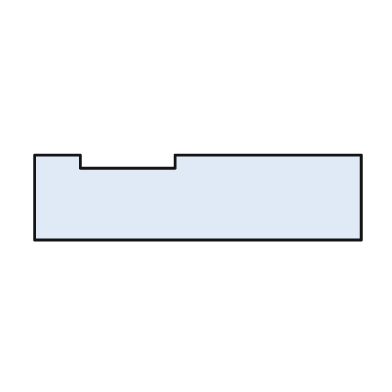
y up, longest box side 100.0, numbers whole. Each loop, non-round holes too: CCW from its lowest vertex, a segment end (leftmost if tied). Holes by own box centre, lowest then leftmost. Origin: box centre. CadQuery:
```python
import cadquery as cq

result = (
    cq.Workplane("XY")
    .moveTo(-50.0, -13.0)
    .lineTo(50.0, -13.0)
    .lineTo(50.0, 13.0)
    .lineTo(-7.0, 13.0)
    .lineTo(-7.0, 9.0)
    .lineTo(-36.0, 9.0)
    .lineTo(-36.0, 13.0)
    .lineTo(-50.0, 13.0)
    .close()
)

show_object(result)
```